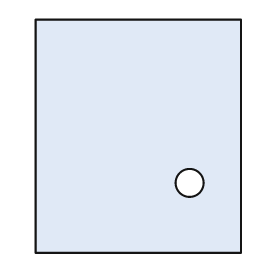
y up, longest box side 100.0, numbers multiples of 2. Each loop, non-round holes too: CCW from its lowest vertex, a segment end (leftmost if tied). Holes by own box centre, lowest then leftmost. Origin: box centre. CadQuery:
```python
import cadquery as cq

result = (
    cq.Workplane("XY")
    .moveTo(-44.0, -50.0)
    .lineTo(44.0, -50.0)
    .lineTo(44.0, 50.0)
    .lineTo(-44.0, 50.0)
    .close()
    .moveTo(22.0, -20.0)
    .circle(6.0)
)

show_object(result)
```